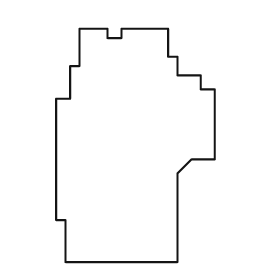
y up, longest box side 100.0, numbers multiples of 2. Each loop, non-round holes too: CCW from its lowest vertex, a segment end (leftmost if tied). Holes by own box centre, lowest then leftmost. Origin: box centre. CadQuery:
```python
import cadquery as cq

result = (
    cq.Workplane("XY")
    .moveTo(-30.0, -50.0)
    .lineTo(18.0, -50.0)
    .lineTo(18.0, -12.0)
    .lineTo(24.0, -6.0)
    .lineTo(34.0, -6.0)
    .lineTo(34.0, 24.0)
    .lineTo(28.0, 24.0)
    .lineTo(28.0, 30.0)
    .lineTo(18.0, 30.0)
    .lineTo(18.0, 38.0)
    .lineTo(14.0, 38.0)
    .lineTo(14.0, 50.0)
    .lineTo(-6.0, 50.0)
    .lineTo(-6.0, 46.0)
    .lineTo(-12.0, 46.0)
    .lineTo(-12.0, 50.0)
    .lineTo(-24.0, 50.0)
    .lineTo(-24.0, 34.0)
    .lineTo(-28.0, 34.0)
    .lineTo(-28.0, 20.0)
    .lineTo(-34.0, 20.0)
    .lineTo(-34.0, -32.0)
    .lineTo(-30.0, -32.0)
    .close()
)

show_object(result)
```